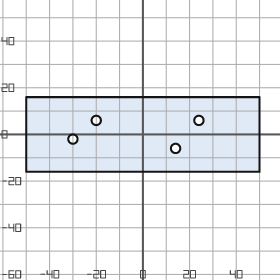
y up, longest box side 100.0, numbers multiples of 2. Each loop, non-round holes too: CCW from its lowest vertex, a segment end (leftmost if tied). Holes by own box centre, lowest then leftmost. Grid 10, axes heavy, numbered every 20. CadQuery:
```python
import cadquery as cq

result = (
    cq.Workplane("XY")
    .moveTo(-50.0, -16.0)
    .lineTo(50.0, -16.0)
    .lineTo(50.0, 16.0)
    .lineTo(-50.0, 16.0)
    .close()
    .moveTo(14.0, -6.0)
    .circle(2.0)
    .moveTo(-30.0, -2.0)
    .circle(2.0)
    .moveTo(-20.0, 6.0)
    .circle(2.0)
    .moveTo(24.0, 6.0)
    .circle(2.0)
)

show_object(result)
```